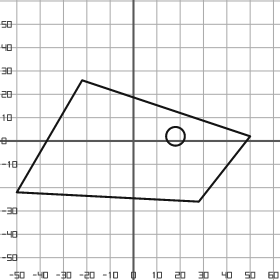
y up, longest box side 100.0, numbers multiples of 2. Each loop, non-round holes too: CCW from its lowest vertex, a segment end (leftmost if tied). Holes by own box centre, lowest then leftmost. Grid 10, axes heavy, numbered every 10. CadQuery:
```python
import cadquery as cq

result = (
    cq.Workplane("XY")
    .moveTo(28.0, -26.0)
    .lineTo(50.0, 2.0)
    .lineTo(-22.0, 26.0)
    .lineTo(-50.0, -22.0)
    .close()
    .moveTo(18.0, 2.0)
    .circle(4.0)
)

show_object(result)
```